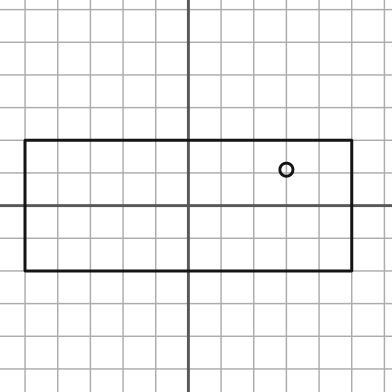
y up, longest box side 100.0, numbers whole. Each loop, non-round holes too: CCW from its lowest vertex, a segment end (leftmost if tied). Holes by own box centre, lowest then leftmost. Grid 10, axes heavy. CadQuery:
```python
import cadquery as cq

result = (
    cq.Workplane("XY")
    .moveTo(-50.0, -20.0)
    .lineTo(50.0, -20.0)
    .lineTo(50.0, 20.0)
    .lineTo(-50.0, 20.0)
    .close()
    .moveTo(30.0, 11.0)
    .circle(2.0)
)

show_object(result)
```